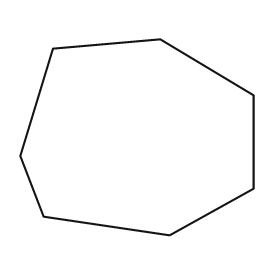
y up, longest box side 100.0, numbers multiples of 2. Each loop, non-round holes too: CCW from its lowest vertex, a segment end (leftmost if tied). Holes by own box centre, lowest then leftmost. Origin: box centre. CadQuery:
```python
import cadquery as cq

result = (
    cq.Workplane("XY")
    .moveTo(14.0, -42.0)
    .lineTo(50.0, -22.0)
    .lineTo(50.0, 18.0)
    .lineTo(10.0, 42.0)
    .lineTo(-36.0, 38.0)
    .lineTo(-50.0, -8.0)
    .lineTo(-40.0, -34.0)
    .close()
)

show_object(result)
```